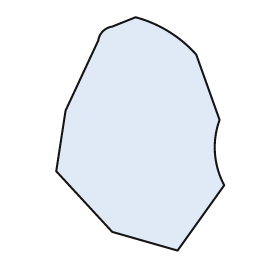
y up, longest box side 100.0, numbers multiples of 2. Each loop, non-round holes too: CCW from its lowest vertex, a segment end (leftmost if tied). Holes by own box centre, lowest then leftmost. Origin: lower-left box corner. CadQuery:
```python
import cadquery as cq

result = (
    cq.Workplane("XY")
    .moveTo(52.0, 0.0)
    .lineTo(72.0, 28.0)
    .threePointArc((68.0, 42.0), (70.0, 56.0))
    .lineTo(60.0, 84.0)
    .threePointArc((48.0, 94.0), (34.0, 100.0))
    .lineTo(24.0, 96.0)
    .threePointArc((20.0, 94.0), (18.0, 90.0))
    .lineTo(4.0, 60.0)
    .lineTo(0.0, 34.0)
    .lineTo(24.0, 8.0)
    .close()
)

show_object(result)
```